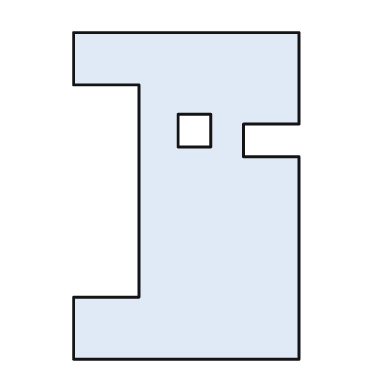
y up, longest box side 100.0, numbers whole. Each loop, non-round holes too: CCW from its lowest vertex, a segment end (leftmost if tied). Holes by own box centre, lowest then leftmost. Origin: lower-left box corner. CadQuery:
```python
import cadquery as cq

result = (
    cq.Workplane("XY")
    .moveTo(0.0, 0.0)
    .lineTo(69.0, 0.0)
    .lineTo(69.0, 62.0)
    .lineTo(52.0, 62.0)
    .lineTo(52.0, 72.0)
    .lineTo(69.0, 72.0)
    .lineTo(69.0, 100.0)
    .lineTo(0.0, 100.0)
    .lineTo(0.0, 84.0)
    .lineTo(20.0, 84.0)
    .lineTo(20.0, 19.0)
    .lineTo(0.0, 19.0)
    .close()
    .moveTo(32.0, 65.0)
    .lineTo(42.0, 65.0)
    .lineTo(42.0, 75.0)
    .lineTo(32.0, 75.0)
    .close()
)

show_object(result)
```